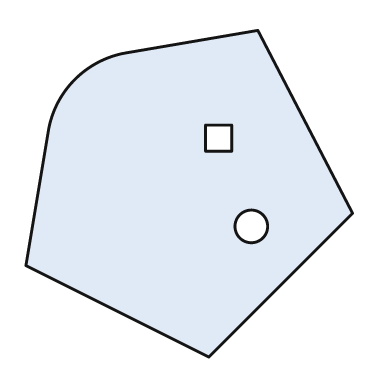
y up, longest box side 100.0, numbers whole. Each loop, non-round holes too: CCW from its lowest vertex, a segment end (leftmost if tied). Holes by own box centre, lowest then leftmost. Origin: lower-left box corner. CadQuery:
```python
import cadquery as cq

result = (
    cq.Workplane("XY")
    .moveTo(56.0, 0.0)
    .lineTo(100.0, 44.0)
    .lineTo(71.0, 100.0)
    .lineTo(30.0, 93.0)
    .threePointArc((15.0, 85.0), (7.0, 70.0))
    .lineTo(0.0, 28.0)
    .close()
    .moveTo(69.0, 40.0)
    .circle(5.0)
    .moveTo(55.0, 63.0)
    .lineTo(63.0, 63.0)
    .lineTo(63.0, 71.0)
    .lineTo(55.0, 71.0)
    .close()
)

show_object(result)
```